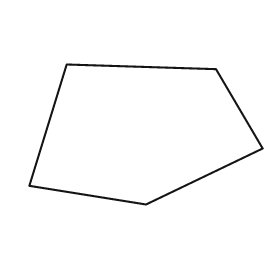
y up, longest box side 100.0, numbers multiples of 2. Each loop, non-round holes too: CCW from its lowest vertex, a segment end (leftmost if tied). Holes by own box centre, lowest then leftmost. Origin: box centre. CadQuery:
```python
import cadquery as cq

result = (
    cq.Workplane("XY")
    .moveTo(0.0, -30.0)
    .lineTo(50.0, -6.0)
    .lineTo(30.0, 28.0)
    .lineTo(-34.0, 30.0)
    .lineTo(-50.0, -22.0)
    .close()
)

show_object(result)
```